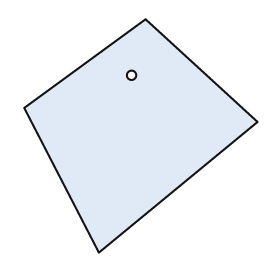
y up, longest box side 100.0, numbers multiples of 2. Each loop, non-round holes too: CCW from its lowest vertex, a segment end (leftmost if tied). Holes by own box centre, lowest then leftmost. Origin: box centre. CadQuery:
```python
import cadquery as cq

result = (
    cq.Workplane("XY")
    .moveTo(-18.0, -50.0)
    .lineTo(50.0, 6.0)
    .lineTo(2.0, 50.0)
    .lineTo(-50.0, 12.0)
    .close()
    .moveTo(-4.0, 26.0)
    .circle(2.0)
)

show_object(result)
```